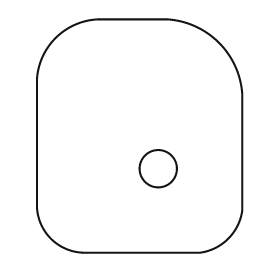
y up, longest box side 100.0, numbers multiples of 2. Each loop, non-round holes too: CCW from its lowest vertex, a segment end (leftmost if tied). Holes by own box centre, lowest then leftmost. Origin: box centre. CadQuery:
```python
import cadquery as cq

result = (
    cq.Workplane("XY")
    .moveTo(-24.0, -50.0)
    .lineTo(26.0, -50.0)
    .threePointArc((38.0, -44.0), (44.0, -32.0))
    .lineTo(44.0, 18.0)
    .threePointArc((34.0, 40.0), (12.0, 50.0))
    .lineTo(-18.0, 50.0)
    .threePointArc((-36.0, 42.0), (-44.0, 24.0))
    .lineTo(-44.0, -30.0)
    .threePointArc((-38.0, -44.0), (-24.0, -50.0))
    .close()
    .moveTo(8.0, -14.0)
    .circle(8.0)
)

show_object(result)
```